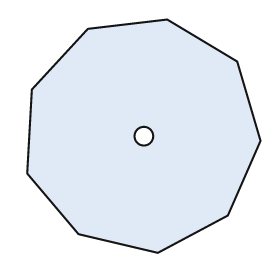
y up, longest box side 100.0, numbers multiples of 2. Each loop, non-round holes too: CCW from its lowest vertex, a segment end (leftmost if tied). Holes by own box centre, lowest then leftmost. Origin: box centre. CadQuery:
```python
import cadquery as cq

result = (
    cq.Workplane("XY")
    .moveTo(6.0, -50.0)
    .lineTo(36.0, -34.0)
    .lineTo(50.0, -2.0)
    .lineTo(40.0, 32.0)
    .lineTo(10.0, 50.0)
    .lineTo(-24.0, 46.0)
    .lineTo(-48.0, 20.0)
    .lineTo(-50.0, -16.0)
    .lineTo(-28.0, -42.0)
    .close()
    .moveTo(0.0, 0.0)
    .circle(4.0)
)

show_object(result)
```